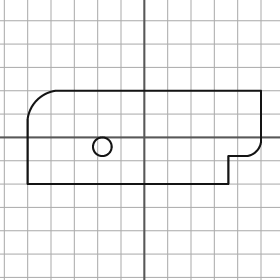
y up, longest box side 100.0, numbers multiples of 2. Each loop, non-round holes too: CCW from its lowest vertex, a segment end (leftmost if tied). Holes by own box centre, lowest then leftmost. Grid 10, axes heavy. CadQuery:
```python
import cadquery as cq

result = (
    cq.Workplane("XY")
    .moveTo(-50.0, -20.0)
    .lineTo(36.0, -20.0)
    .lineTo(36.0, -8.0)
    .lineTo(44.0, -8.0)
    .threePointArc((48.0, -6.0), (50.0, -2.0))
    .lineTo(50.0, 20.0)
    .lineTo(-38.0, 20.0)
    .threePointArc((-46.0, 16.0), (-50.0, 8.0))
    .close()
    .moveTo(-18.0, -4.0)
    .circle(4.0)
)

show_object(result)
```